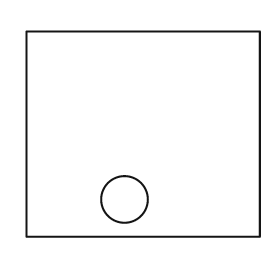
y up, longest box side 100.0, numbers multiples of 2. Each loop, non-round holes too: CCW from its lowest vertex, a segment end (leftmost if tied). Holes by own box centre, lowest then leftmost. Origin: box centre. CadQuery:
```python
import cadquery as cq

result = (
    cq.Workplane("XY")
    .moveTo(-50.0, -44.0)
    .lineTo(50.0, -44.0)
    .lineTo(50.0, 44.0)
    .lineTo(-50.0, 44.0)
    .close()
    .moveTo(-8.0, -28.0)
    .circle(10.0)
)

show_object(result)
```